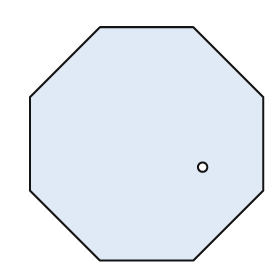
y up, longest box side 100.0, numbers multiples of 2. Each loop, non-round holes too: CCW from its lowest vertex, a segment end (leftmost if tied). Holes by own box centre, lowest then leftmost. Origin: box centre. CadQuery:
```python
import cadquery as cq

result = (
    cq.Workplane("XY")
    .moveTo(-20.0, -50.0)
    .lineTo(20.0, -50.0)
    .lineTo(50.0, -20.0)
    .lineTo(50.0, 20.0)
    .lineTo(20.0, 50.0)
    .lineTo(-20.0, 50.0)
    .lineTo(-50.0, 20.0)
    .lineTo(-50.0, -20.0)
    .close()
    .moveTo(24.0, -10.0)
    .circle(2.0)
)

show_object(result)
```